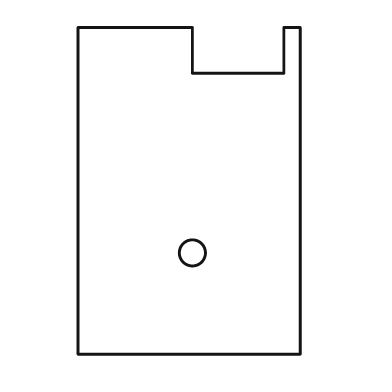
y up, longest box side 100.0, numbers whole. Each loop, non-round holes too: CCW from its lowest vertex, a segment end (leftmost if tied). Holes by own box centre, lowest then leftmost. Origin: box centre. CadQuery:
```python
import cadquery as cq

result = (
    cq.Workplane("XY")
    .moveTo(-34.0, -50.0)
    .lineTo(34.0, -50.0)
    .lineTo(34.0, 50.0)
    .lineTo(29.0, 50.0)
    .lineTo(29.0, 36.0)
    .lineTo(1.0, 36.0)
    .lineTo(1.0, 50.0)
    .lineTo(-34.0, 50.0)
    .close()
    .moveTo(1.0, -19.0)
    .circle(4.0)
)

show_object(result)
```